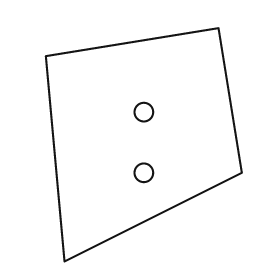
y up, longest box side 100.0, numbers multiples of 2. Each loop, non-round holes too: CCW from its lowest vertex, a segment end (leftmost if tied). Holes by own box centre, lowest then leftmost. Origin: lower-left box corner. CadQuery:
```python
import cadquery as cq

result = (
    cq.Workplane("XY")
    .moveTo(8.0, 0.0)
    .lineTo(84.0, 38.0)
    .lineTo(74.0, 100.0)
    .lineTo(0.0, 88.0)
    .close()
    .moveTo(42.0, 38.0)
    .circle(4.0)
    .moveTo(42.0, 64.0)
    .circle(4.0)
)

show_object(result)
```